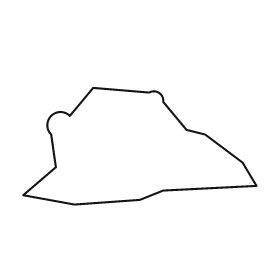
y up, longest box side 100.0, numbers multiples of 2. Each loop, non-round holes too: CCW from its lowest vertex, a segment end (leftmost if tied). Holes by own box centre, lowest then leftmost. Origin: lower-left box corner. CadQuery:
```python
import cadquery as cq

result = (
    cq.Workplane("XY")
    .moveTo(22.0, 0.0)
    .lineTo(50.0, 2.0)
    .lineTo(60.0, 6.0)
    .lineTo(100.0, 8.0)
    .lineTo(94.0, 18.0)
    .lineTo(78.0, 30.0)
    .lineTo(70.0, 32.0)
    .lineTo(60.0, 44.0)
    .threePointArc((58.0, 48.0), (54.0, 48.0))
    .lineTo(30.0, 50.0)
    .lineTo(20.0, 38.0)
    .threePointArc((12.0, 38.0), (12.0, 30.0))
    .lineTo(14.0, 16.0)
    .lineTo(0.0, 4.0)
    .close()
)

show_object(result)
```